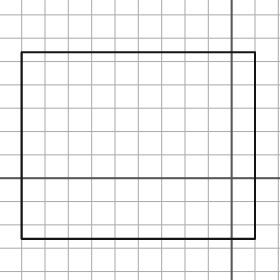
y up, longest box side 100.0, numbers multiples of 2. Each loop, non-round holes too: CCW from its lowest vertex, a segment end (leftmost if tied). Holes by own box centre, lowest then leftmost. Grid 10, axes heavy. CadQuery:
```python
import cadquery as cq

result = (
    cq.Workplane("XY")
    .moveTo(-90.0, -26.0)
    .lineTo(10.0, -26.0)
    .lineTo(10.0, 54.0)
    .lineTo(-90.0, 54.0)
    .close()
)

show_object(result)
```